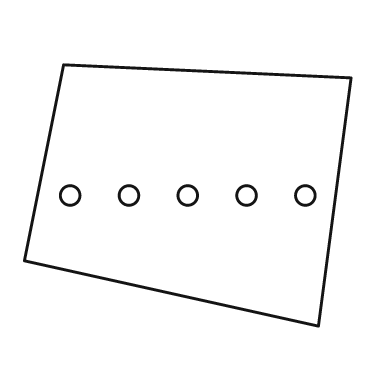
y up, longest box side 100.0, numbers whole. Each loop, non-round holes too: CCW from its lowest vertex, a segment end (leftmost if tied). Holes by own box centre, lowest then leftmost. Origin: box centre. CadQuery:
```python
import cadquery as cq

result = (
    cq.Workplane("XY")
    .moveTo(40.0, -40.0)
    .lineTo(50.0, 36.0)
    .lineTo(-38.0, 40.0)
    .lineTo(-50.0, -20.0)
    .close()
    .moveTo(-36.0, 0.0)
    .circle(3.0)
    .moveTo(-18.0, 0.0)
    .circle(3.0)
    .moveTo(0.0, 0.0)
    .circle(3.0)
    .moveTo(18.0, 0.0)
    .circle(3.0)
    .moveTo(36.0, 0.0)
    .circle(3.0)
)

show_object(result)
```